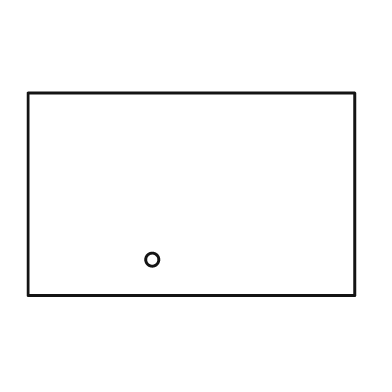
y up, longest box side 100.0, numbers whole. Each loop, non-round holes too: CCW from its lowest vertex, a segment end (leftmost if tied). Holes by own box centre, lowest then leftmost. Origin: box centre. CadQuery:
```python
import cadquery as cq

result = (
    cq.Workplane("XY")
    .moveTo(-50.0, -31.0)
    .lineTo(50.0, -31.0)
    .lineTo(50.0, 31.0)
    .lineTo(-50.0, 31.0)
    .close()
    .moveTo(-12.0, -20.0)
    .circle(2.0)
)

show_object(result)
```